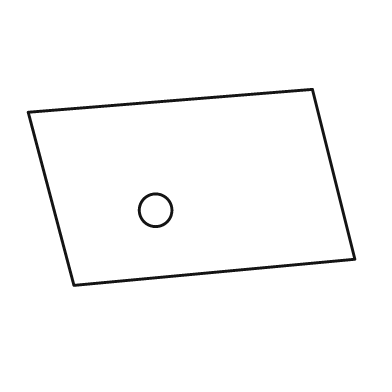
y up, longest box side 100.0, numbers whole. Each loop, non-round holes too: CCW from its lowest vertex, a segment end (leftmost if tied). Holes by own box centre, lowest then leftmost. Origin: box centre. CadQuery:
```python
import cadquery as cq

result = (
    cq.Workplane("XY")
    .moveTo(-36.0, -30.0)
    .lineTo(50.0, -22.0)
    .lineTo(37.0, 30.0)
    .lineTo(-50.0, 23.0)
    .close()
    .moveTo(-11.0, -7.0)
    .circle(5.0)
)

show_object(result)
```